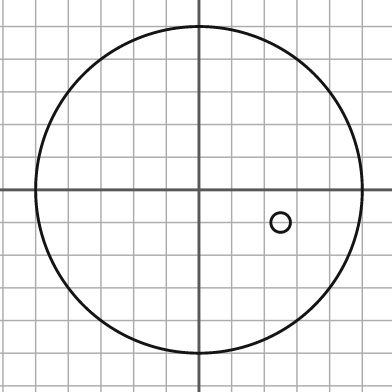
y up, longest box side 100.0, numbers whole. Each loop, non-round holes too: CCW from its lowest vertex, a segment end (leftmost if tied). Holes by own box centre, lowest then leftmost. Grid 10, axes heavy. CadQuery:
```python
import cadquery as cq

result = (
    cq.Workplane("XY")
    .moveTo(0.0, 0.0)
    .circle(50.0)
    .moveTo(25.0, -10.0)
    .circle(3.0)
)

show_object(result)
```